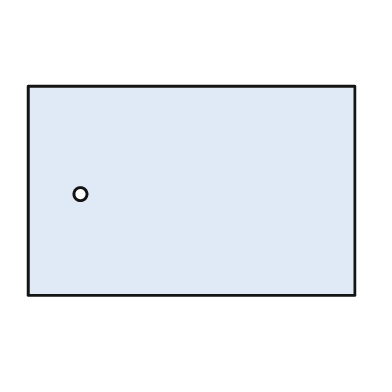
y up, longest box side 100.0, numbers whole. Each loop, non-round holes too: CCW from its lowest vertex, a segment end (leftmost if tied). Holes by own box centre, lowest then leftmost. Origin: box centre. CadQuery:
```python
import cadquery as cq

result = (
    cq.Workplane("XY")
    .moveTo(-50.0, -32.0)
    .lineTo(50.0, -32.0)
    .lineTo(50.0, 32.0)
    .lineTo(-50.0, 32.0)
    .close()
    .moveTo(-34.0, -1.0)
    .circle(2.0)
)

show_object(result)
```